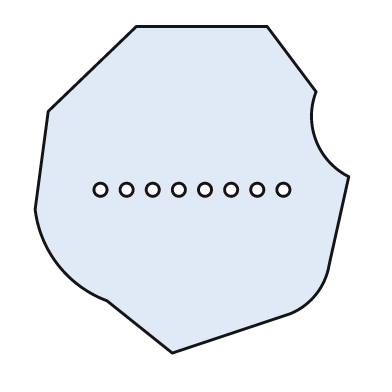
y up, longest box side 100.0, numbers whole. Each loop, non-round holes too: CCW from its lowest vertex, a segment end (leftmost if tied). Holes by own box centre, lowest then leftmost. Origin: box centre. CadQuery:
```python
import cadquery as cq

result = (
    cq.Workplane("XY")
    .moveTo(-6.0, -50.0)
    .lineTo(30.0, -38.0)
    .threePointArc((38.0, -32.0), (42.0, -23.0))
    .lineTo(48.0, 4.0)
    .threePointArc((38.0, 15.0), (38.0, 30.0))
    .lineTo(23.0, 50.0)
    .lineTo(-17.0, 50.0)
    .lineTo(-44.0, 24.0)
    .lineTo(-48.0, -6.0)
    .threePointArc((-41.0, -23.0), (-26.0, -34.0))
    .close()
    .moveTo(-28.0, 0.0)
    .circle(2.0)
    .moveTo(-20.0, 0.0)
    .circle(2.0)
    .moveTo(-12.0, 0.0)
    .circle(2.0)
    .moveTo(-4.0, 0.0)
    .circle(2.0)
    .moveTo(4.0, 0.0)
    .circle(2.0)
    .moveTo(12.0, 0.0)
    .circle(2.0)
    .moveTo(20.0, 0.0)
    .circle(2.0)
    .moveTo(28.0, 0.0)
    .circle(2.0)
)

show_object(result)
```